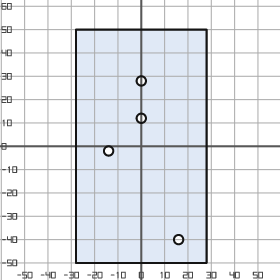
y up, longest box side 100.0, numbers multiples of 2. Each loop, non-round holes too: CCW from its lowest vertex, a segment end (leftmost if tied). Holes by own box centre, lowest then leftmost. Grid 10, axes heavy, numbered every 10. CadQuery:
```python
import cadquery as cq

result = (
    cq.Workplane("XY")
    .moveTo(-28.0, -50.0)
    .lineTo(28.0, -50.0)
    .lineTo(28.0, 50.0)
    .lineTo(-28.0, 50.0)
    .close()
    .moveTo(16.0, -40.0)
    .circle(2.0)
    .moveTo(-14.0, -2.0)
    .circle(2.0)
    .moveTo(0.0, 12.0)
    .circle(2.0)
    .moveTo(0.0, 28.0)
    .circle(2.0)
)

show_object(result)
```